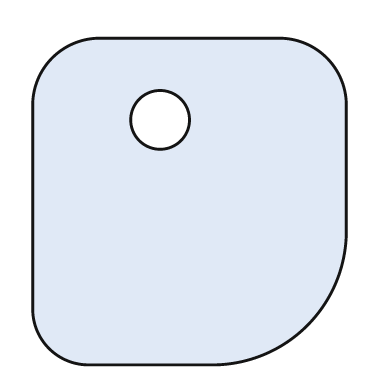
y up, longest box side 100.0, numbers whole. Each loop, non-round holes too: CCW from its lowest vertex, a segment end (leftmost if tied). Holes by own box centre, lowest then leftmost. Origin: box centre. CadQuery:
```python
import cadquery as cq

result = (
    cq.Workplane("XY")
    .moveTo(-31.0, -50.0)
    .lineTo(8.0, -50.0)
    .threePointArc((36.0, -38.0), (48.0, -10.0))
    .lineTo(48.0, 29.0)
    .threePointArc((42.0, 44.0), (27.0, 50.0))
    .lineTo(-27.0, 50.0)
    .threePointArc((-42.0, 44.0), (-48.0, 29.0))
    .lineTo(-48.0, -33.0)
    .threePointArc((-43.0, -45.0), (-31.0, -50.0))
    .close()
    .moveTo(-9.0, 25.0)
    .circle(9.0)
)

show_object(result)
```